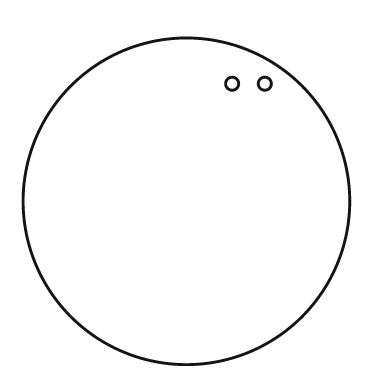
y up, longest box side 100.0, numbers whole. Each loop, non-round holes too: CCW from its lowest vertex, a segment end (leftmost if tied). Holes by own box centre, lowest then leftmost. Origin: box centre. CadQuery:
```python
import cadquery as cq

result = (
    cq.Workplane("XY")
    .moveTo(0.0, 0.0)
    .circle(50.0)
    .moveTo(14.0, 36.0)
    .circle(2.0)
    .moveTo(24.0, 36.0)
    .circle(2.0)
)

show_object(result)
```